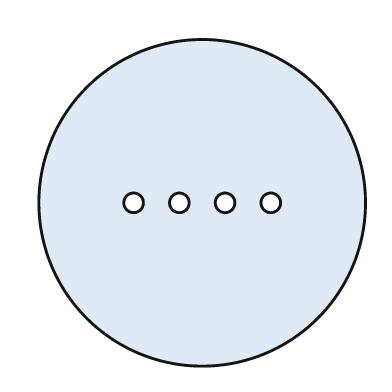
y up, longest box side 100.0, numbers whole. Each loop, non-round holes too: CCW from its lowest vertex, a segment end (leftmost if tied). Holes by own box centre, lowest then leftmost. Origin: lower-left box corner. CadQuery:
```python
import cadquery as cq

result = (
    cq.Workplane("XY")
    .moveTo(50.0, 50.0)
    .circle(50.0)
    .moveTo(29.0, 50.0)
    .circle(3.0)
    .moveTo(43.0, 50.0)
    .circle(3.0)
    .moveTo(57.0, 50.0)
    .circle(3.0)
    .moveTo(71.0, 50.0)
    .circle(3.0)
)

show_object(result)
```